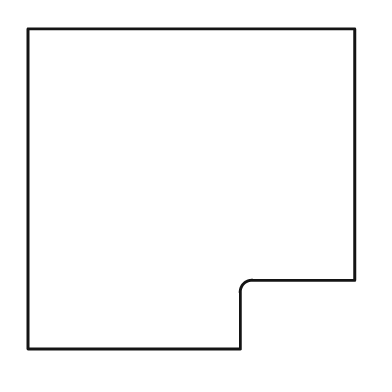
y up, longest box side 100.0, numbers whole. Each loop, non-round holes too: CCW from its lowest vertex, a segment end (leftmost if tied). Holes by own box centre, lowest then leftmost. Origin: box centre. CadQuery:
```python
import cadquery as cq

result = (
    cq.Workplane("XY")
    .moveTo(-50.0, -49.0)
    .lineTo(15.0, -49.0)
    .lineTo(15.0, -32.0)
    .threePointArc((16.0, -29.0), (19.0, -28.0))
    .lineTo(50.0, -28.0)
    .lineTo(50.0, 49.0)
    .lineTo(-50.0, 49.0)
    .close()
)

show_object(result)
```